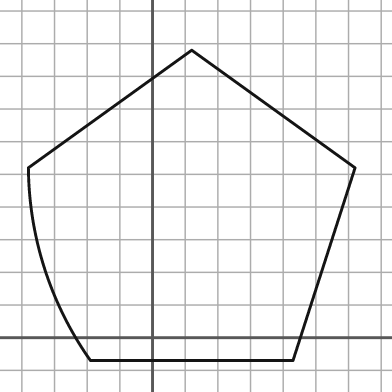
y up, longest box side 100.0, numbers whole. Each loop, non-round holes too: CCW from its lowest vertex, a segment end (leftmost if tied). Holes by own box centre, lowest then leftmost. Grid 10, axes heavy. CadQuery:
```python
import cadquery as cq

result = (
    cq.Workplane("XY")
    .moveTo(-19.0, -7.0)
    .lineTo(43.0, -7.0)
    .lineTo(62.0, 52.0)
    .lineTo(12.0, 88.0)
    .lineTo(-38.0, 52.0)
    .threePointArc((-33.0, 21.0), (-19.0, -7.0))
    .close()
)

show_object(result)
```